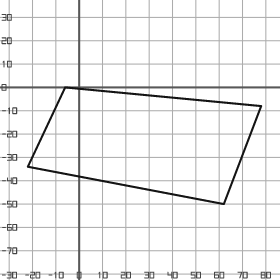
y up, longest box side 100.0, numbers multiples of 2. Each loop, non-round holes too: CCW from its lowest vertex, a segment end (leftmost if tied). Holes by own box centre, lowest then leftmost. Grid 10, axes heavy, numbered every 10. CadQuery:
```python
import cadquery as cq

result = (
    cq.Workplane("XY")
    .moveTo(62.0, -50.0)
    .lineTo(78.0, -8.0)
    .lineTo(-6.0, 0.0)
    .lineTo(-22.0, -34.0)
    .close()
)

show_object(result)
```